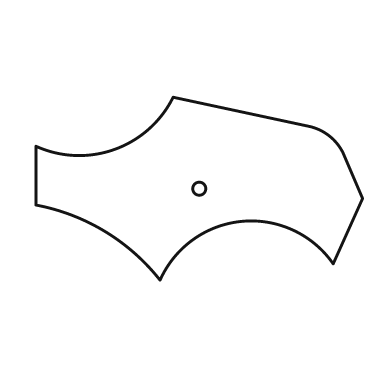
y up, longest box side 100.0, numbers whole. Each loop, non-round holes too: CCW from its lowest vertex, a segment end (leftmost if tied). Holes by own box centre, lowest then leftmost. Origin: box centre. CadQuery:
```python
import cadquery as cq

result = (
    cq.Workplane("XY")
    .moveTo(-12.0, -28.0)
    .threePointArc((13.0, -10.0), (41.0, -23.0))
    .lineTo(50.0, -3.0)
    .lineTo(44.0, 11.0)
    .threePointArc((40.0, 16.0), (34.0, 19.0))
    .lineTo(-8.0, 28.0)
    .threePointArc((-26.0, 12.0), (-50.0, 13.0))
    .lineTo(-50.0, -5.0)
    .threePointArc((-29.0, -13.0), (-12.0, -28.0))
    .close()
    .moveTo(0.0, 0.0)
    .circle(2.0)
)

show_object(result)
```